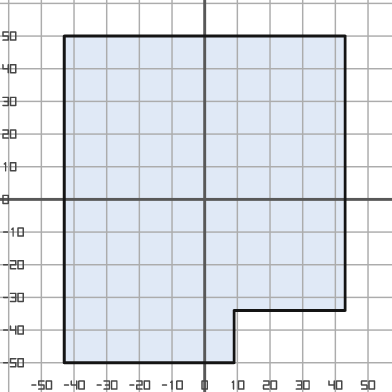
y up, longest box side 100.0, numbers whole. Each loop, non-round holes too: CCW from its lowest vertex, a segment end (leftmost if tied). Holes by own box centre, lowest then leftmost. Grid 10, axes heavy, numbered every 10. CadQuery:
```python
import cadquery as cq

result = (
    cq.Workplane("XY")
    .moveTo(-43.0, -50.0)
    .lineTo(9.0, -50.0)
    .lineTo(9.0, -34.0)
    .lineTo(43.0, -34.0)
    .lineTo(43.0, 50.0)
    .lineTo(-43.0, 50.0)
    .close()
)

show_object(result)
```